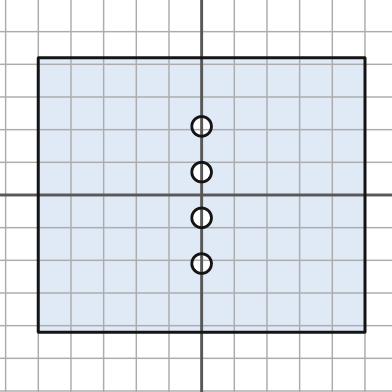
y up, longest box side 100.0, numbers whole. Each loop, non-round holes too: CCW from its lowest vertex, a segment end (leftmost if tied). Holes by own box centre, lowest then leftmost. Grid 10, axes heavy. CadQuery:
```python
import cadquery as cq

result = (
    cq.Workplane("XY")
    .moveTo(-50.0, -42.0)
    .lineTo(50.0, -42.0)
    .lineTo(50.0, 42.0)
    .lineTo(-50.0, 42.0)
    .close()
    .moveTo(0.0, -21.0)
    .circle(3.0)
    .moveTo(0.0, -7.0)
    .circle(3.0)
    .moveTo(0.0, 7.0)
    .circle(3.0)
    .moveTo(0.0, 21.0)
    .circle(3.0)
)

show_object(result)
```